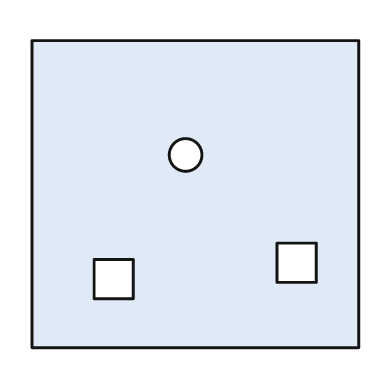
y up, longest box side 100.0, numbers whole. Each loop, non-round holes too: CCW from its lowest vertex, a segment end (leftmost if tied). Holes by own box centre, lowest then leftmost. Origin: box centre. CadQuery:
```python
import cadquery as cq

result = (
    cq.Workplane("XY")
    .moveTo(-50.0, -47.0)
    .lineTo(50.0, -47.0)
    .lineTo(50.0, 47.0)
    .lineTo(-50.0, 47.0)
    .close()
    .moveTo(-31.0, -32.0)
    .lineTo(-19.0, -32.0)
    .lineTo(-19.0, -20.0)
    .lineTo(-31.0, -20.0)
    .close()
    .moveTo(25.0, -27.0)
    .lineTo(37.0, -27.0)
    .lineTo(37.0, -15.0)
    .lineTo(25.0, -15.0)
    .close()
    .moveTo(-3.0, 12.0)
    .circle(5.0)
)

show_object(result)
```